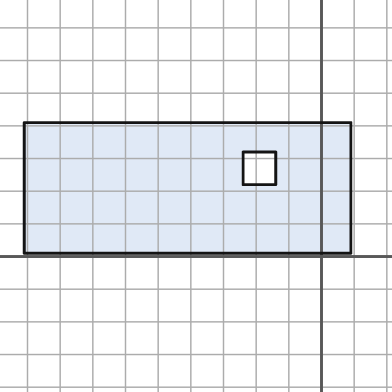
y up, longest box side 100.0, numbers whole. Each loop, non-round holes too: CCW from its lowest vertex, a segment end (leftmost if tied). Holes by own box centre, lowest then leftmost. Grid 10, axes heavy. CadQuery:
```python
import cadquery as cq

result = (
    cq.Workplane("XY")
    .moveTo(-91.0, 1.0)
    .lineTo(9.0, 1.0)
    .lineTo(9.0, 41.0)
    .lineTo(-91.0, 41.0)
    .close()
    .moveTo(-24.0, 22.0)
    .lineTo(-14.0, 22.0)
    .lineTo(-14.0, 32.0)
    .lineTo(-24.0, 32.0)
    .close()
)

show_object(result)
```